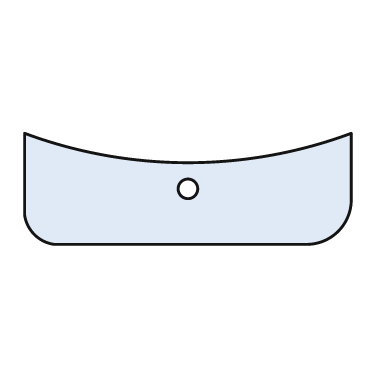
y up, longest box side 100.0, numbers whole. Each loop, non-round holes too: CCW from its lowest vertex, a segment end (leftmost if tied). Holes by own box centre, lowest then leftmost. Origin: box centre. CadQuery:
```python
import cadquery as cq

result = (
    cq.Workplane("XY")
    .moveTo(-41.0, -17.0)
    .lineTo(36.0, -17.0)
    .threePointArc((46.0, -13.0), (50.0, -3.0))
    .lineTo(50.0, 17.0)
    .threePointArc((0.0, 8.0), (-50.0, 17.0))
    .lineTo(-50.0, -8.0)
    .threePointArc((-47.0, -14.0), (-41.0, -17.0))
    .close()
    .moveTo(0.0, 0.0)
    .circle(3.0)
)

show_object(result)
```